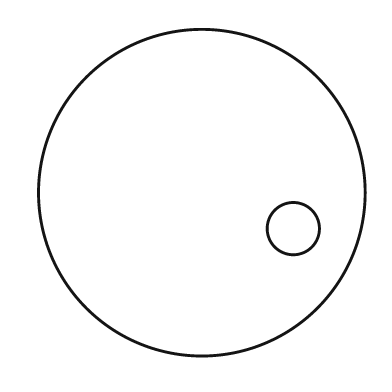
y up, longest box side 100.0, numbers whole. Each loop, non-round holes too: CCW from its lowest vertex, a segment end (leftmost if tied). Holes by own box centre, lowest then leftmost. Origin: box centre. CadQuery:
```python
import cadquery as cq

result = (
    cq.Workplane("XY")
    .moveTo(0.0, 0.0)
    .circle(50.0)
    .moveTo(28.0, -11.0)
    .circle(8.0)
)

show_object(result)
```